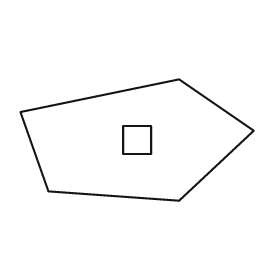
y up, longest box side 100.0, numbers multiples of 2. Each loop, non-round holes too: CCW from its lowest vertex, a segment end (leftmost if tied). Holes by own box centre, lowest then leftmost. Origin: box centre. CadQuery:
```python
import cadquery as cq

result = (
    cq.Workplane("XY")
    .moveTo(18.0, -26.0)
    .lineTo(50.0, 4.0)
    .lineTo(18.0, 26.0)
    .lineTo(-50.0, 12.0)
    .lineTo(-38.0, -22.0)
    .close()
    .moveTo(-6.0, -6.0)
    .lineTo(6.0, -6.0)
    .lineTo(6.0, 6.0)
    .lineTo(-6.0, 6.0)
    .close()
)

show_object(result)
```